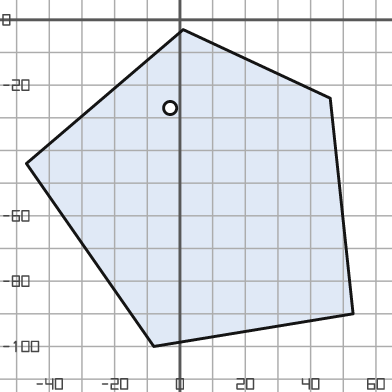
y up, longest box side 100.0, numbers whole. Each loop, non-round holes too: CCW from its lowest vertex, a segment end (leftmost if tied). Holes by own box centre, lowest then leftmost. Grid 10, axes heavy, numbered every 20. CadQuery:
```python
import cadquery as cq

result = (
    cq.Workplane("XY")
    .moveTo(-8.0, -100.0)
    .lineTo(53.0, -90.0)
    .lineTo(46.0, -24.0)
    .lineTo(1.0, -3.0)
    .lineTo(-47.0, -44.0)
    .close()
    .moveTo(-3.0, -27.0)
    .circle(2.0)
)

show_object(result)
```